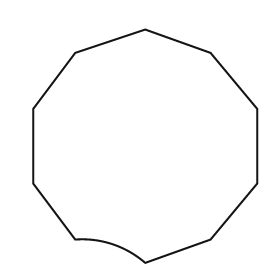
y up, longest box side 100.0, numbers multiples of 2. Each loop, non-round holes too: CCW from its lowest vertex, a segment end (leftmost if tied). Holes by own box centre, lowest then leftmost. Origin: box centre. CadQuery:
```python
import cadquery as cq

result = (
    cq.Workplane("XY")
    .moveTo(0.0, -50.0)
    .lineTo(28.0, -40.0)
    .lineTo(48.0, -16.0)
    .lineTo(48.0, 16.0)
    .lineTo(28.0, 40.0)
    .lineTo(0.0, 50.0)
    .lineTo(-30.0, 40.0)
    .lineTo(-48.0, 16.0)
    .lineTo(-48.0, -16.0)
    .lineTo(-30.0, -40.0)
    .threePointArc((-14.0, -42.0), (0.0, -50.0))
    .close()
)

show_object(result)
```